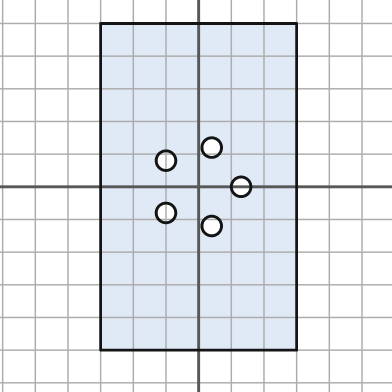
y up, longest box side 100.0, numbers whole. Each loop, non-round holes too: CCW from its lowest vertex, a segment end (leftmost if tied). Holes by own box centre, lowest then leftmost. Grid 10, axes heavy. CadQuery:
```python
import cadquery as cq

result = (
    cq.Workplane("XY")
    .moveTo(-30.0, -50.0)
    .lineTo(30.0, -50.0)
    .lineTo(30.0, 50.0)
    .lineTo(-30.0, 50.0)
    .close()
    .moveTo(4.0, -12.0)
    .circle(3.0)
    .moveTo(-10.0, -8.0)
    .circle(3.0)
    .moveTo(13.0, 0.0)
    .circle(3.0)
    .moveTo(-10.0, 8.0)
    .circle(3.0)
    .moveTo(4.0, 12.0)
    .circle(3.0)
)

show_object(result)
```